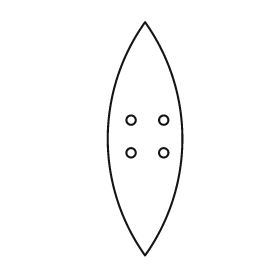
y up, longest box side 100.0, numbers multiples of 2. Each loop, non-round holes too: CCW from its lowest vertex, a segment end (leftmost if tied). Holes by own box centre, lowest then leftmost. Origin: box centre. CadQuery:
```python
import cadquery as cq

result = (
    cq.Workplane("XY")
    .moveTo(0.0, -50.0)
    .threePointArc((16.0, 0.0), (0.0, 50.0))
    .threePointArc((-16.0, 0.0), (0.0, -50.0))
    .close()
    .moveTo(-6.0, -6.0)
    .circle(2.0)
    .moveTo(8.0, -6.0)
    .circle(2.0)
    .moveTo(-6.0, 8.0)
    .circle(2.0)
    .moveTo(8.0, 8.0)
    .circle(2.0)
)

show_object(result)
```